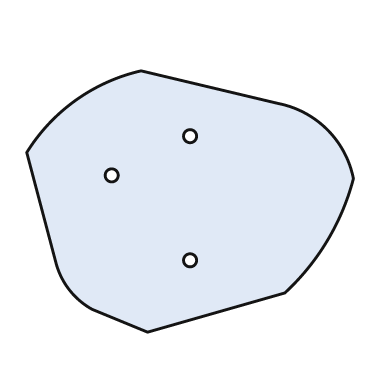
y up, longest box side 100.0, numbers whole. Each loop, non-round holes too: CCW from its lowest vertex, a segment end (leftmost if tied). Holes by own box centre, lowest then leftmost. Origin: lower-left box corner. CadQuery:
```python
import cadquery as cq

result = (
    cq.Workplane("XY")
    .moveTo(37.0, 0.0)
    .lineTo(79.0, 12.0)
    .threePointArc((92.0, 28.0), (100.0, 47.0))
    .threePointArc((92.0, 62.0), (77.0, 70.0))
    .lineTo(35.0, 80.0)
    .threePointArc((15.0, 71.0), (0.0, 55.0))
    .lineTo(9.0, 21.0)
    .threePointArc((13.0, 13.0), (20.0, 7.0))
    .close()
    .moveTo(50.0, 22.0)
    .circle(2.0)
    .moveTo(26.0, 48.0)
    .circle(2.0)
    .moveTo(50.0, 60.0)
    .circle(2.0)
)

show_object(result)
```